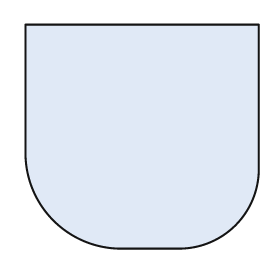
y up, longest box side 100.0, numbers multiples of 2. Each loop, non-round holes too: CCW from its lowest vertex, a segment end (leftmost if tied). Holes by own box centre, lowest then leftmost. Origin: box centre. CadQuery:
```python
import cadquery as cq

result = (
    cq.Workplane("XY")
    .moveTo(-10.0, -48.0)
    .lineTo(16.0, -48.0)
    .threePointArc((40.0, -38.0), (50.0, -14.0))
    .lineTo(50.0, 48.0)
    .lineTo(-50.0, 48.0)
    .lineTo(-50.0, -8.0)
    .threePointArc((-38.0, -36.0), (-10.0, -48.0))
    .close()
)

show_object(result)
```